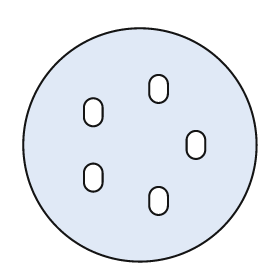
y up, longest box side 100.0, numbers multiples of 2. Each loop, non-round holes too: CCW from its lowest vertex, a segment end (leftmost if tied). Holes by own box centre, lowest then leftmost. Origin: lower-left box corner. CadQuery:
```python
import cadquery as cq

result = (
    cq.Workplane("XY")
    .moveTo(50.0, 50.0)
    .circle(50.0)
    .moveTo(54.0, 24.0)
    .threePointArc((58.0, 20.0), (62.0, 24.0))
    .lineTo(62.0, 28.0)
    .threePointArc((58.0, 32.0), (54.0, 28.0))
    .close()
    .moveTo(26.0, 34.0)
    .threePointArc((30.0, 30.0), (34.0, 34.0))
    .lineTo(34.0, 38.0)
    .threePointArc((30.0, 42.0), (26.0, 38.0))
    .close()
    .moveTo(70.0, 48.0)
    .threePointArc((74.0, 44.0), (78.0, 48.0))
    .lineTo(78.0, 52.0)
    .threePointArc((74.0, 56.0), (70.0, 52.0))
    .close()
    .moveTo(26.0, 62.0)
    .threePointArc((30.0, 58.0), (34.0, 62.0))
    .lineTo(34.0, 66.0)
    .threePointArc((30.0, 70.0), (26.0, 66.0))
    .close()
    .moveTo(54.0, 72.0)
    .threePointArc((58.0, 68.0), (62.0, 72.0))
    .lineTo(62.0, 76.0)
    .threePointArc((58.0, 80.0), (54.0, 76.0))
    .close()
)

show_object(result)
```